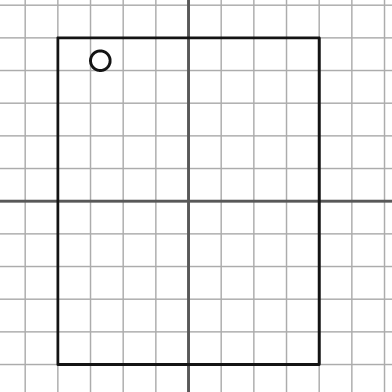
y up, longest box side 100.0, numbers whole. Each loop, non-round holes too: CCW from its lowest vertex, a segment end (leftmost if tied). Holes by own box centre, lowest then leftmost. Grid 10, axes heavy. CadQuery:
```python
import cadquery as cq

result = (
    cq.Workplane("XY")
    .moveTo(-40.0, -50.0)
    .lineTo(40.0, -50.0)
    .lineTo(40.0, 50.0)
    .lineTo(-40.0, 50.0)
    .close()
    .moveTo(-27.0, 43.0)
    .circle(3.0)
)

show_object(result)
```